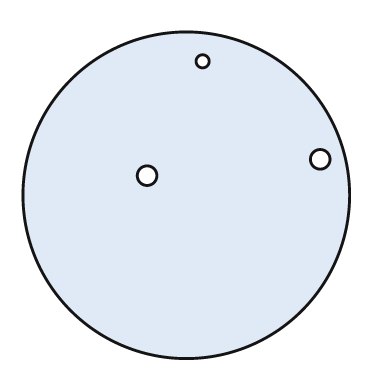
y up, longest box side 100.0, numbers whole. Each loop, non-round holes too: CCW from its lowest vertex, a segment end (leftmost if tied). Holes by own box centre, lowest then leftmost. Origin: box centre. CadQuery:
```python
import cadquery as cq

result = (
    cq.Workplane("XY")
    .moveTo(0.0, 0.0)
    .circle(50.0)
    .moveTo(-12.0, 6.0)
    .circle(3.0)
    .moveTo(41.0, 11.0)
    .circle(3.0)
    .moveTo(5.0, 41.0)
    .circle(2.0)
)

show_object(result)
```